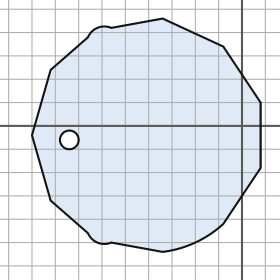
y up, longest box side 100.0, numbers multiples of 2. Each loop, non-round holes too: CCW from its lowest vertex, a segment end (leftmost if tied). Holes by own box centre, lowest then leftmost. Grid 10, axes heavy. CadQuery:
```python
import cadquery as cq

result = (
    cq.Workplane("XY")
    .moveTo(-34.0, -54.0)
    .threePointArc((-20.0, -50.0), (-8.0, -42.0))
    .lineTo(8.0, -18.0)
    .lineTo(8.0, 10.0)
    .lineTo(-8.0, 34.0)
    .lineTo(-34.0, 46.0)
    .lineTo(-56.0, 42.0)
    .threePointArc((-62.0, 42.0), (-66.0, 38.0))
    .lineTo(-82.0, 24.0)
    .lineTo(-90.0, -4.0)
    .lineTo(-82.0, -32.0)
    .lineTo(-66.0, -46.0)
    .threePointArc((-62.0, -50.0), (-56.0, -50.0))
    .close()
    .moveTo(-74.0, -6.0)
    .circle(4.0)
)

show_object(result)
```